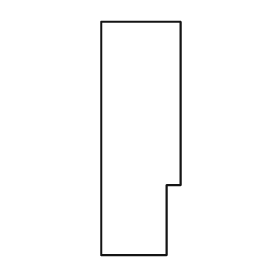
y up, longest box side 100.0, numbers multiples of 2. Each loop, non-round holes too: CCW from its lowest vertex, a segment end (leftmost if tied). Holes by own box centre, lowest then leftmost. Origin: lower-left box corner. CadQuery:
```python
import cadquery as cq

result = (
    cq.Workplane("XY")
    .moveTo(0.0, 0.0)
    .lineTo(28.0, 0.0)
    .lineTo(28.0, 30.0)
    .lineTo(34.0, 30.0)
    .lineTo(34.0, 100.0)
    .lineTo(0.0, 100.0)
    .close()
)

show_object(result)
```